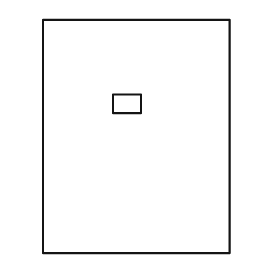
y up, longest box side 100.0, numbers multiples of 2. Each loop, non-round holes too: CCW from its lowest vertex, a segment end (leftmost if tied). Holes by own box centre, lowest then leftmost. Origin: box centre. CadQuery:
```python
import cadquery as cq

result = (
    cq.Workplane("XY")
    .moveTo(-40.0, -50.0)
    .lineTo(40.0, -50.0)
    .lineTo(40.0, 50.0)
    .lineTo(-40.0, 50.0)
    .close()
    .moveTo(-10.0, 10.0)
    .lineTo(2.0, 10.0)
    .lineTo(2.0, 18.0)
    .lineTo(-10.0, 18.0)
    .close()
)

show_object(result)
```